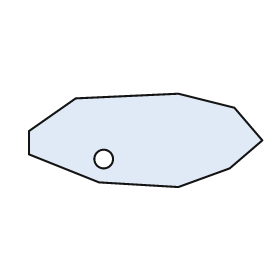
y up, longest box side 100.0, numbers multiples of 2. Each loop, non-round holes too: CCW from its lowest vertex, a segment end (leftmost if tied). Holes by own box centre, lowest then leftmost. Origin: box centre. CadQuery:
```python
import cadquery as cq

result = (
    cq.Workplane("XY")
    .moveTo(14.0, -20.0)
    .lineTo(36.0, -12.0)
    .lineTo(50.0, 0.0)
    .lineTo(38.0, 14.0)
    .lineTo(14.0, 20.0)
    .lineTo(-30.0, 18.0)
    .lineTo(-50.0, 4.0)
    .lineTo(-50.0, -6.0)
    .lineTo(-20.0, -18.0)
    .close()
    .moveTo(-18.0, -8.0)
    .circle(4.0)
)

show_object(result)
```